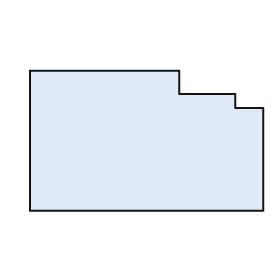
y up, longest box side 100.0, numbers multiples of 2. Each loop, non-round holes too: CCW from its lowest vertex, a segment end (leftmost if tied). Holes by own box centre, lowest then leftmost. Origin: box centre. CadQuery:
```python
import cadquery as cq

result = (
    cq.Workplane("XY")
    .moveTo(-50.0, -30.0)
    .lineTo(50.0, -30.0)
    .lineTo(50.0, 14.0)
    .lineTo(38.0, 14.0)
    .lineTo(38.0, 20.0)
    .lineTo(14.0, 20.0)
    .lineTo(14.0, 30.0)
    .lineTo(-50.0, 30.0)
    .close()
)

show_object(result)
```